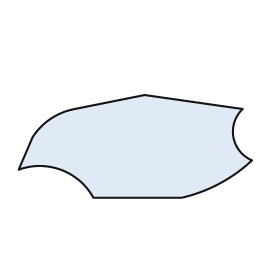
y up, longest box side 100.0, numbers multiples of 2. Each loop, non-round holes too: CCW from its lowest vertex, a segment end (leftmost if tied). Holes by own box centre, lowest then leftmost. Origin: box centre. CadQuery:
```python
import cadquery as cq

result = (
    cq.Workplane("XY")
    .moveTo(-18.0, -22.0)
    .lineTo(20.0, -22.0)
    .threePointArc((36.0, -16.0), (50.0, -6.0))
    .threePointArc((42.0, 4.0), (46.0, 16.0))
    .lineTo(4.0, 22.0)
    .lineTo(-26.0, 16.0)
    .threePointArc((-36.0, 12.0), (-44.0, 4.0))
    .lineTo(-50.0, -10.0)
    .threePointArc((-32.0, -10.0), (-18.0, -22.0))
    .close()
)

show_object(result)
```